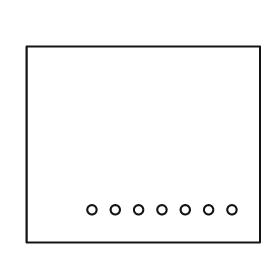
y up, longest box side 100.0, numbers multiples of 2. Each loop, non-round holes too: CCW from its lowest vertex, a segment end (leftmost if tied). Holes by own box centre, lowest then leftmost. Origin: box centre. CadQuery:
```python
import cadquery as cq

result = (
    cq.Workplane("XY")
    .moveTo(-50.0, -42.0)
    .lineTo(50.0, -42.0)
    .lineTo(50.0, 42.0)
    .lineTo(-50.0, 42.0)
    .close()
    .moveTo(-22.0, -28.0)
    .circle(2.0)
    .moveTo(-12.0, -28.0)
    .circle(2.0)
    .moveTo(-2.0, -28.0)
    .circle(2.0)
    .moveTo(8.0, -28.0)
    .circle(2.0)
    .moveTo(18.0, -28.0)
    .circle(2.0)
    .moveTo(28.0, -28.0)
    .circle(2.0)
    .moveTo(38.0, -28.0)
    .circle(2.0)
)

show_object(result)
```